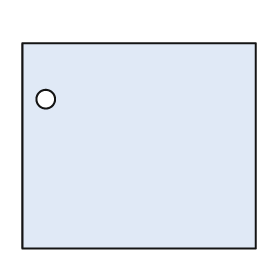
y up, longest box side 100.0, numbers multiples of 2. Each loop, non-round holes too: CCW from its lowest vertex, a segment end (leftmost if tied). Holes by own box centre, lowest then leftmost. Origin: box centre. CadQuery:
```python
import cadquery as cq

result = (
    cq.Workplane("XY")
    .moveTo(-50.0, -44.0)
    .lineTo(50.0, -44.0)
    .lineTo(50.0, 44.0)
    .lineTo(-50.0, 44.0)
    .close()
    .moveTo(-40.0, 20.0)
    .circle(4.0)
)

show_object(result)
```